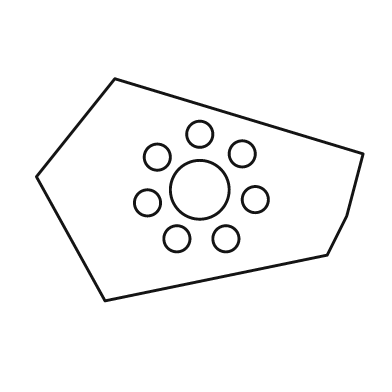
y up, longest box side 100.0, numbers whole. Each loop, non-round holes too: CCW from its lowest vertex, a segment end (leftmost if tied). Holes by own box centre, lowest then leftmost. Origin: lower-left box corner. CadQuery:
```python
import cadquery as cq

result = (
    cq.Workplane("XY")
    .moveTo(21.0, 0.0)
    .lineTo(89.0, 14.0)
    .lineTo(95.0, 26.0)
    .lineTo(100.0, 45.0)
    .lineTo(24.0, 68.0)
    .lineTo(0.0, 38.0)
    .close()
    .moveTo(43.0, 19.0)
    .circle(4.0)
    .moveTo(58.0, 19.0)
    .circle(4.0)
    .moveTo(34.0, 30.0)
    .circle(4.0)
    .moveTo(67.0, 31.0)
    .circle(4.0)
    .moveTo(50.0, 34.0)
    .circle(9.0)
    .moveTo(37.0, 44.0)
    .circle(4.0)
    .moveTo(63.0, 45.0)
    .circle(4.0)
    .moveTo(50.0, 51.0)
    .circle(4.0)
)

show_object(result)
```